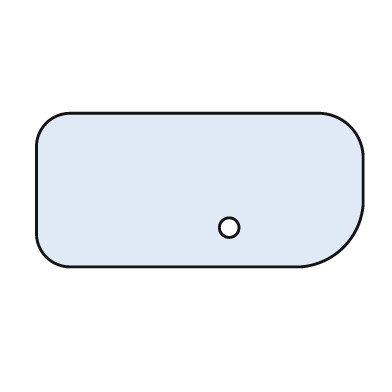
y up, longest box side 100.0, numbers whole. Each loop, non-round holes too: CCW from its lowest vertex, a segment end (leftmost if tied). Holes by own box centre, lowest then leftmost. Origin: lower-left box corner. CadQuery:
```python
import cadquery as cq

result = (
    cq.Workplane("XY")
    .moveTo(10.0, 0.0)
    .lineTo(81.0, 0.0)
    .threePointArc((94.0, 6.0), (100.0, 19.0))
    .lineTo(100.0, 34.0)
    .threePointArc((96.0, 43.0), (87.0, 47.0))
    .lineTo(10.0, 47.0)
    .threePointArc((3.0, 44.0), (0.0, 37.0))
    .lineTo(0.0, 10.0)
    .threePointArc((3.0, 3.0), (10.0, 0.0))
    .close()
    .moveTo(59.0, 12.0)
    .circle(3.0)
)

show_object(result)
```